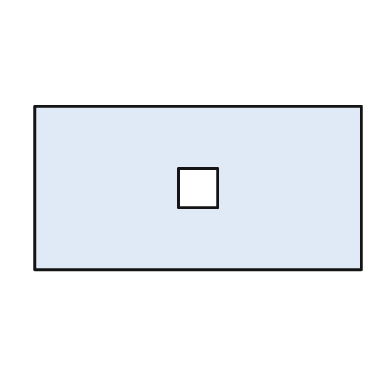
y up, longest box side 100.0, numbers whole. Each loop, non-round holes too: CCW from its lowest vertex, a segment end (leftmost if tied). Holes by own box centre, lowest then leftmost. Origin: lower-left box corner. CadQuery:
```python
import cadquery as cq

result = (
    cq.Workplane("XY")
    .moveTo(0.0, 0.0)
    .lineTo(100.0, 0.0)
    .lineTo(100.0, 50.0)
    .lineTo(0.0, 50.0)
    .close()
    .moveTo(44.0, 19.0)
    .lineTo(56.0, 19.0)
    .lineTo(56.0, 31.0)
    .lineTo(44.0, 31.0)
    .close()
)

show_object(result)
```